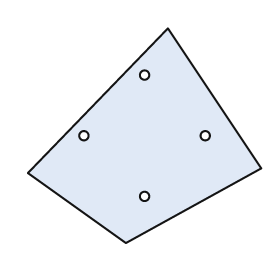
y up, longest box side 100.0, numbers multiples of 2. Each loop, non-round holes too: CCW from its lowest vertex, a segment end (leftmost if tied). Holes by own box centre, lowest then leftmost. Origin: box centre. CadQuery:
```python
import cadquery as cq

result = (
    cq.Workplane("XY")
    .moveTo(-8.0, -46.0)
    .lineTo(50.0, -14.0)
    .lineTo(10.0, 46.0)
    .lineTo(-50.0, -16.0)
    .close()
    .moveTo(0.0, -26.0)
    .circle(2.0)
    .moveTo(-26.0, 0.0)
    .circle(2.0)
    .moveTo(26.0, 0.0)
    .circle(2.0)
    .moveTo(0.0, 26.0)
    .circle(2.0)
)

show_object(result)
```